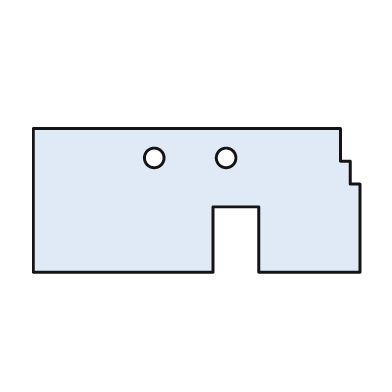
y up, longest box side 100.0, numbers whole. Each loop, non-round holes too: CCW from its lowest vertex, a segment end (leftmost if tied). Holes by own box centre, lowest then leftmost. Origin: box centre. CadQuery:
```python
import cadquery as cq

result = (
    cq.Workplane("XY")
    .moveTo(-50.0, -22.0)
    .lineTo(5.0, -22.0)
    .lineTo(5.0, -2.0)
    .lineTo(19.0, -2.0)
    .lineTo(19.0, -22.0)
    .lineTo(50.0, -22.0)
    .lineTo(50.0, 5.0)
    .lineTo(47.0, 5.0)
    .lineTo(47.0, 12.0)
    .lineTo(44.0, 12.0)
    .lineTo(44.0, 22.0)
    .lineTo(-50.0, 22.0)
    .close()
    .moveTo(-13.0, 13.0)
    .circle(3.0)
    .moveTo(9.0, 13.0)
    .circle(3.0)
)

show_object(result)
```